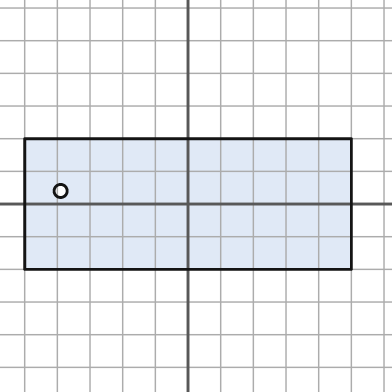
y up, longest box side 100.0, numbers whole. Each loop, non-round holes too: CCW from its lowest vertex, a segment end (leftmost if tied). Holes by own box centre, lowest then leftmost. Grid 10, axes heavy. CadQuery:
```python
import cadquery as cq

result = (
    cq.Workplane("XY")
    .moveTo(-50.0, -20.0)
    .lineTo(50.0, -20.0)
    .lineTo(50.0, 20.0)
    .lineTo(-50.0, 20.0)
    .close()
    .moveTo(-39.0, 4.0)
    .circle(2.0)
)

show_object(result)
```